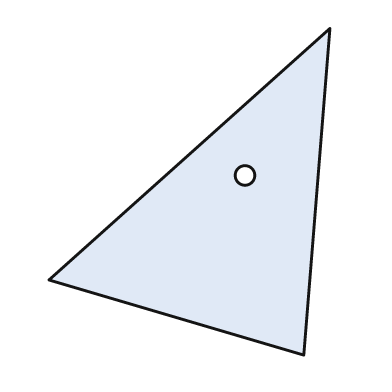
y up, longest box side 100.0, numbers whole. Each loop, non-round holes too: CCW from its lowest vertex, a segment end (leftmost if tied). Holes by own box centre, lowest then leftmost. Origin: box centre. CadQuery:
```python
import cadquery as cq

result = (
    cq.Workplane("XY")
    .moveTo(35.0, -50.0)
    .lineTo(43.0, 50.0)
    .lineTo(-43.0, -27.0)
    .close()
    .moveTo(17.0, 5.0)
    .circle(3.0)
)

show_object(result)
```